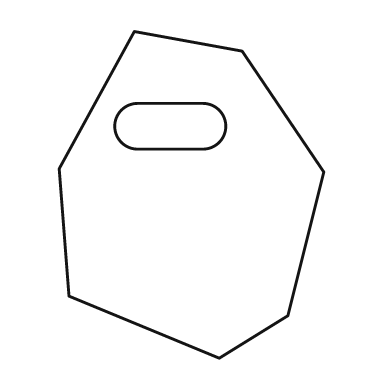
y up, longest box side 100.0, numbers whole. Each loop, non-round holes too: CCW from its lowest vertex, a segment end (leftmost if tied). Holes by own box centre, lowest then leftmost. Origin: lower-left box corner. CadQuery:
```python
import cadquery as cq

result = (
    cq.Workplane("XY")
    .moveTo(49.0, 0.0)
    .lineTo(70.0, 13.0)
    .lineTo(81.0, 57.0)
    .lineTo(56.0, 94.0)
    .lineTo(23.0, 100.0)
    .lineTo(0.0, 58.0)
    .lineTo(3.0, 19.0)
    .close()
    .moveTo(24.0, 64.0)
    .lineTo(44.0, 64.0)
    .threePointArc((51.0, 71.0), (44.0, 78.0))
    .lineTo(24.0, 78.0)
    .threePointArc((17.0, 71.0), (24.0, 64.0))
    .close()
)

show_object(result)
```